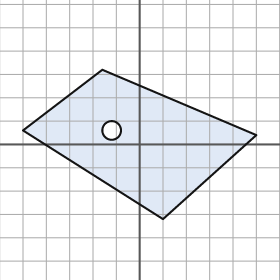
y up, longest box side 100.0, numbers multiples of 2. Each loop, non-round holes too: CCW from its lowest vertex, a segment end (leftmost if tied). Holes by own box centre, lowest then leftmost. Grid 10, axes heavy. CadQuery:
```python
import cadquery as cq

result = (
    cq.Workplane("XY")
    .moveTo(10.0, -32.0)
    .lineTo(50.0, 4.0)
    .lineTo(-16.0, 32.0)
    .lineTo(-50.0, 6.0)
    .close()
    .moveTo(-12.0, 6.0)
    .circle(4.0)
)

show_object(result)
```